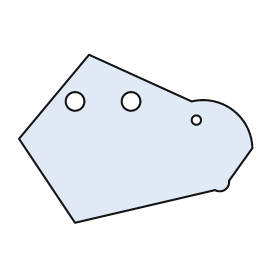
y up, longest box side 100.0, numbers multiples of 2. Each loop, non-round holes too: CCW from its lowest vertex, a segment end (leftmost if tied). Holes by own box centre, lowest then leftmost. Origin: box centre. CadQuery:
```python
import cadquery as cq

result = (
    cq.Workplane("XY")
    .moveTo(-26.0, -36.0)
    .lineTo(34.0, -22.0)
    .threePointArc((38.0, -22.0), (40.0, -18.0))
    .lineTo(50.0, -4.0)
    .threePointArc((42.0, 12.0), (24.0, 16.0))
    .lineTo(-20.0, 36.0)
    .lineTo(-50.0, 0.0)
    .close()
    .moveTo(26.0, 8.0)
    .circle(2.0)
    .moveTo(-26.0, 16.0)
    .circle(4.0)
    .moveTo(-2.0, 16.0)
    .circle(4.0)
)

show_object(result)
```